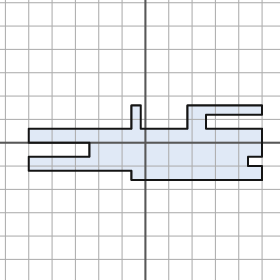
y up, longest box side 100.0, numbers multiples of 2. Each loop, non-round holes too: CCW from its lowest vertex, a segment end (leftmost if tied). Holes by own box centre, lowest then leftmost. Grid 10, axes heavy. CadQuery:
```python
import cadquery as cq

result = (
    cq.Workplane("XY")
    .moveTo(-6.0, -16.0)
    .lineTo(50.0, -16.0)
    .lineTo(50.0, -10.0)
    .lineTo(44.0, -10.0)
    .lineTo(44.0, -6.0)
    .lineTo(50.0, -6.0)
    .lineTo(50.0, 6.0)
    .lineTo(26.0, 6.0)
    .lineTo(26.0, 12.0)
    .lineTo(50.0, 12.0)
    .lineTo(50.0, 16.0)
    .lineTo(18.0, 16.0)
    .lineTo(18.0, 6.0)
    .lineTo(-2.0, 6.0)
    .lineTo(-2.0, 16.0)
    .lineTo(-6.0, 16.0)
    .lineTo(-6.0, 6.0)
    .lineTo(-50.0, 6.0)
    .lineTo(-50.0, 0.0)
    .lineTo(-24.0, 0.0)
    .lineTo(-24.0, -6.0)
    .lineTo(-50.0, -6.0)
    .lineTo(-50.0, -12.0)
    .lineTo(-6.0, -12.0)
    .close()
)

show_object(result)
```